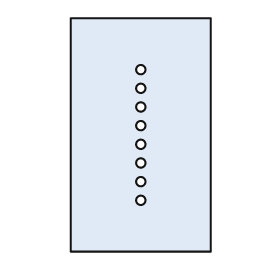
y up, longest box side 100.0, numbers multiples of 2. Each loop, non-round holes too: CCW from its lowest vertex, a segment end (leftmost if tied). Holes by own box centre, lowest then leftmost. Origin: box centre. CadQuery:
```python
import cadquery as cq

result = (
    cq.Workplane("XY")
    .moveTo(-30.0, -50.0)
    .lineTo(30.0, -50.0)
    .lineTo(30.0, 50.0)
    .lineTo(-30.0, 50.0)
    .close()
    .moveTo(0.0, -28.0)
    .circle(2.0)
    .moveTo(0.0, -20.0)
    .circle(2.0)
    .moveTo(0.0, -12.0)
    .circle(2.0)
    .moveTo(0.0, -4.0)
    .circle(2.0)
    .moveTo(0.0, 4.0)
    .circle(2.0)
    .moveTo(0.0, 12.0)
    .circle(2.0)
    .moveTo(0.0, 20.0)
    .circle(2.0)
    .moveTo(0.0, 28.0)
    .circle(2.0)
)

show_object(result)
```